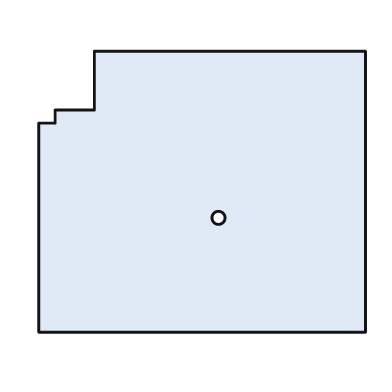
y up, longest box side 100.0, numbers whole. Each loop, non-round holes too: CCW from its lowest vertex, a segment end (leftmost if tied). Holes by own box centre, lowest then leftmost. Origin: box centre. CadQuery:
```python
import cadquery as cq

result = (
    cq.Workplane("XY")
    .moveTo(-50.0, -43.0)
    .lineTo(50.0, -43.0)
    .lineTo(50.0, 43.0)
    .lineTo(-33.0, 43.0)
    .lineTo(-33.0, 25.0)
    .lineTo(-45.0, 25.0)
    .lineTo(-45.0, 21.0)
    .lineTo(-50.0, 21.0)
    .close()
    .moveTo(5.0, -8.0)
    .circle(2.0)
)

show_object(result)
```